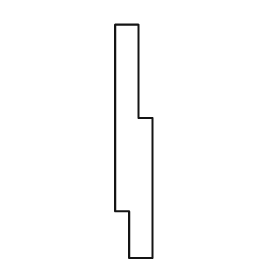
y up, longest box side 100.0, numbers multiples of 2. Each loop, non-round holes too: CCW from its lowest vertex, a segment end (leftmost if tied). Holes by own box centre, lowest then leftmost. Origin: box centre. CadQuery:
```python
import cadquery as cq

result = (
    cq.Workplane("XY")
    .moveTo(-2.0, -50.0)
    .lineTo(8.0, -50.0)
    .lineTo(8.0, 10.0)
    .lineTo(2.0, 10.0)
    .lineTo(2.0, 50.0)
    .lineTo(-8.0, 50.0)
    .lineTo(-8.0, -30.0)
    .lineTo(-2.0, -30.0)
    .close()
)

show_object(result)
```